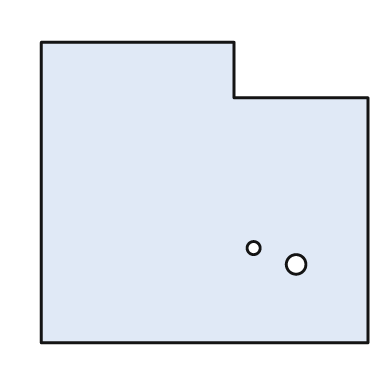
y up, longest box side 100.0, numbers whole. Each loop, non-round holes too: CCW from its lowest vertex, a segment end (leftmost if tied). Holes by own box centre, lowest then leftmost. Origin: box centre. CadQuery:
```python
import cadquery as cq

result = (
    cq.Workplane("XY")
    .moveTo(-50.0, -46.0)
    .lineTo(50.0, -46.0)
    .lineTo(50.0, 29.0)
    .lineTo(9.0, 29.0)
    .lineTo(9.0, 46.0)
    .lineTo(-50.0, 46.0)
    .close()
    .moveTo(28.0, -22.0)
    .circle(3.0)
    .moveTo(15.0, -17.0)
    .circle(2.0)
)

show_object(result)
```